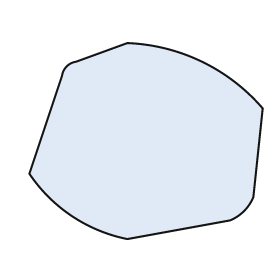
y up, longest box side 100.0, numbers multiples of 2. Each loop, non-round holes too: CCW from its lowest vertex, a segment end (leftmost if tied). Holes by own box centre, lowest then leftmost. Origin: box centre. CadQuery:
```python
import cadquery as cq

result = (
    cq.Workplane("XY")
    .moveTo(-8.0, -42.0)
    .lineTo(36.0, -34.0)
    .threePointArc((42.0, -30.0), (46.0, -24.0))
    .lineTo(50.0, 14.0)
    .threePointArc((24.0, 34.0), (-8.0, 42.0))
    .lineTo(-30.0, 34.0)
    .threePointArc((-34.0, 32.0), (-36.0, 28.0))
    .lineTo(-50.0, -14.0)
    .threePointArc((-32.0, -32.0), (-8.0, -42.0))
    .close()
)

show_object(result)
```